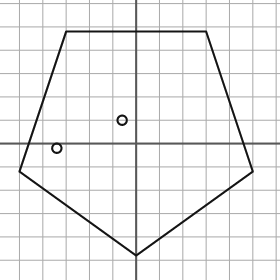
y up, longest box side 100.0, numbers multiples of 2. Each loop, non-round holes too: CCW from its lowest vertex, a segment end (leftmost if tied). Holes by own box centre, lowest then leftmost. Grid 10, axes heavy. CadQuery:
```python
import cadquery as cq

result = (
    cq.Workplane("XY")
    .moveTo(0.0, -48.0)
    .lineTo(50.0, -12.0)
    .lineTo(30.0, 48.0)
    .lineTo(-30.0, 48.0)
    .lineTo(-50.0, -12.0)
    .close()
    .moveTo(-34.0, -2.0)
    .circle(2.0)
    .moveTo(-6.0, 10.0)
    .circle(2.0)
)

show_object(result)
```